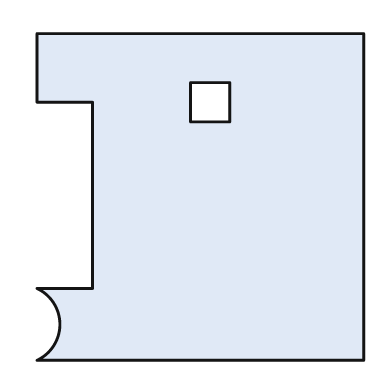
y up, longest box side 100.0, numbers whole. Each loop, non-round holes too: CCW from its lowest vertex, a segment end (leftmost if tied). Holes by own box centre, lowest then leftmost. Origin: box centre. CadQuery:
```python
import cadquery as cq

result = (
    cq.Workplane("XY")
    .moveTo(-50.0, -50.0)
    .lineTo(50.0, -50.0)
    .lineTo(50.0, 50.0)
    .lineTo(-50.0, 50.0)
    .lineTo(-50.0, 29.0)
    .lineTo(-33.0, 29.0)
    .lineTo(-33.0, -28.0)
    .lineTo(-50.0, -28.0)
    .threePointArc((-43.0, -39.0), (-50.0, -50.0))
    .close()
    .moveTo(-3.0, 23.0)
    .lineTo(9.0, 23.0)
    .lineTo(9.0, 35.0)
    .lineTo(-3.0, 35.0)
    .close()
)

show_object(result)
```